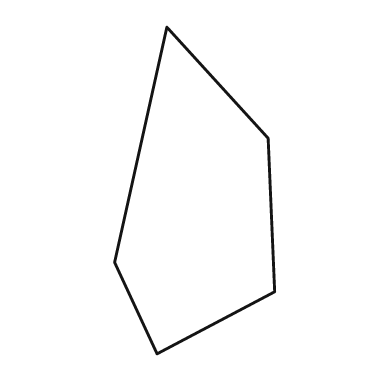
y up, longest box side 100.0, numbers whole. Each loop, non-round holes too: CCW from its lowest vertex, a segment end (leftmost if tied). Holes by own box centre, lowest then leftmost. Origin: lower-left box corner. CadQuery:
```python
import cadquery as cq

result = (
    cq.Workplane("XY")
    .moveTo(13.0, 0.0)
    .lineTo(49.0, 19.0)
    .lineTo(47.0, 66.0)
    .lineTo(16.0, 100.0)
    .lineTo(0.0, 28.0)
    .close()
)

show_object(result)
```